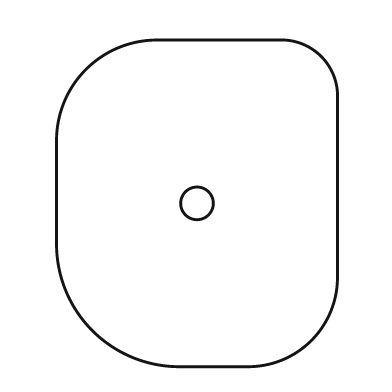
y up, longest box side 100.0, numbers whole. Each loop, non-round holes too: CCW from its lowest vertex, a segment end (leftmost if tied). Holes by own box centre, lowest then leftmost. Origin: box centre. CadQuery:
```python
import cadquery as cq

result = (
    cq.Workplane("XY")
    .moveTo(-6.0, -50.0)
    .lineTo(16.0, -50.0)
    .threePointArc((35.0, -42.0), (43.0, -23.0))
    .lineTo(43.0, 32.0)
    .threePointArc((38.0, 45.0), (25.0, 50.0))
    .lineTo(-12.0, 50.0)
    .threePointArc((-34.0, 41.0), (-43.0, 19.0))
    .lineTo(-43.0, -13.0)
    .threePointArc((-32.0, -39.0), (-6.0, -50.0))
    .close()
    .moveTo(0.0, 0.0)
    .circle(5.0)
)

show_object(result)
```